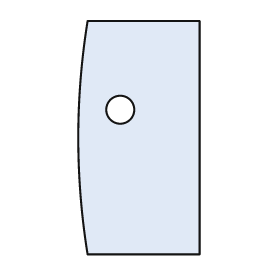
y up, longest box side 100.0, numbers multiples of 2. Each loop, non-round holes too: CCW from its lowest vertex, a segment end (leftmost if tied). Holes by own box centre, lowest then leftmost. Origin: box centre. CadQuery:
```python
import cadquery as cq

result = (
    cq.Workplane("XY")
    .moveTo(-22.0, -50.0)
    .lineTo(26.0, -50.0)
    .lineTo(26.0, 50.0)
    .lineTo(-22.0, 50.0)
    .threePointArc((-26.0, 0.0), (-22.0, -50.0))
    .close()
    .moveTo(-8.0, 12.0)
    .circle(6.0)
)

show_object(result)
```